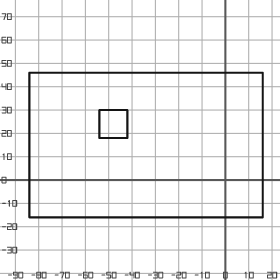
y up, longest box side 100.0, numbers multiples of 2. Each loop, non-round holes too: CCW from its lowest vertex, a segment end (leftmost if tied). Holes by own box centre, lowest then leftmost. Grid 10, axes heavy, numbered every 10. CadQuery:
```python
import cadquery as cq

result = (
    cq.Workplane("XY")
    .moveTo(-84.0, -16.0)
    .lineTo(16.0, -16.0)
    .lineTo(16.0, 46.0)
    .lineTo(-84.0, 46.0)
    .close()
    .moveTo(-54.0, 18.0)
    .lineTo(-42.0, 18.0)
    .lineTo(-42.0, 30.0)
    .lineTo(-54.0, 30.0)
    .close()
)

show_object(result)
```